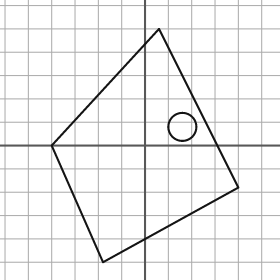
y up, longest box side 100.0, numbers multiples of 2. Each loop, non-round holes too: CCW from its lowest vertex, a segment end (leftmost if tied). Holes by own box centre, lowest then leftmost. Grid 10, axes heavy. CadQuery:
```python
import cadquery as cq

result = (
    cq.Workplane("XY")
    .moveTo(-18.0, -50.0)
    .lineTo(40.0, -18.0)
    .lineTo(6.0, 50.0)
    .lineTo(-40.0, 0.0)
    .close()
    .moveTo(16.0, 8.0)
    .circle(6.0)
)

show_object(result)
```